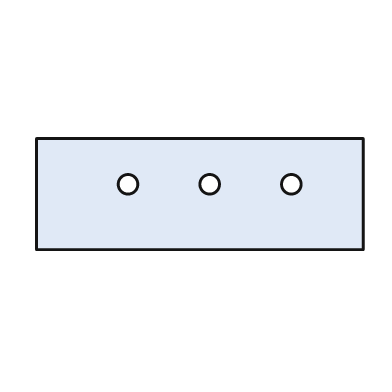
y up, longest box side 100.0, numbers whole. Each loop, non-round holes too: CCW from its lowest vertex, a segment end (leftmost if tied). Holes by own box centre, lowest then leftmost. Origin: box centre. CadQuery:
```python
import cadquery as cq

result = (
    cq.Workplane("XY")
    .moveTo(-50.0, -17.0)
    .lineTo(50.0, -17.0)
    .lineTo(50.0, 17.0)
    .lineTo(-50.0, 17.0)
    .close()
    .moveTo(-22.0, 3.0)
    .circle(3.0)
    .moveTo(3.0, 3.0)
    .circle(3.0)
    .moveTo(28.0, 3.0)
    .circle(3.0)
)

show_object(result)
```